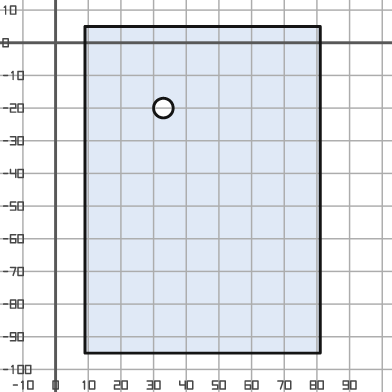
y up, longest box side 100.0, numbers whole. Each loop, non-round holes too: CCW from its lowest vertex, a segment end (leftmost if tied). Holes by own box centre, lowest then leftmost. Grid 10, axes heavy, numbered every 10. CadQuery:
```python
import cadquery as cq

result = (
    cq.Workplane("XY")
    .moveTo(9.0, -95.0)
    .lineTo(81.0, -95.0)
    .lineTo(81.0, 5.0)
    .lineTo(9.0, 5.0)
    .close()
    .moveTo(33.0, -20.0)
    .circle(3.0)
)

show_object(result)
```